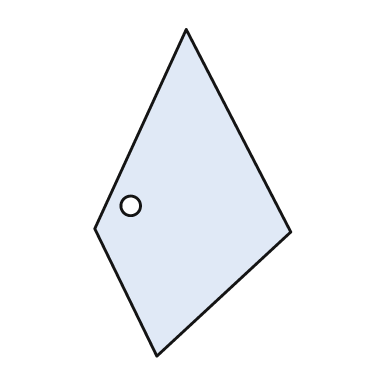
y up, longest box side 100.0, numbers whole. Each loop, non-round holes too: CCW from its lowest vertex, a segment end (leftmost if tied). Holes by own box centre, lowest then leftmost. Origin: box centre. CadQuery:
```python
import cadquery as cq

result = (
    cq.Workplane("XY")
    .moveTo(-11.0, -50.0)
    .lineTo(30.0, -12.0)
    .lineTo(-2.0, 50.0)
    .lineTo(-30.0, -11.0)
    .close()
    .moveTo(-19.0, -4.0)
    .circle(3.0)
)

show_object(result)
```